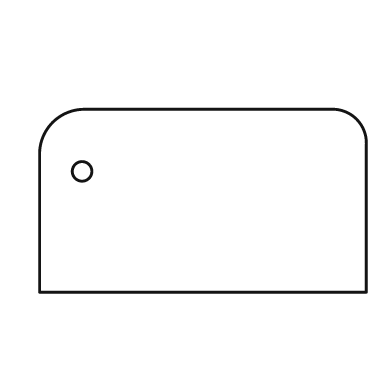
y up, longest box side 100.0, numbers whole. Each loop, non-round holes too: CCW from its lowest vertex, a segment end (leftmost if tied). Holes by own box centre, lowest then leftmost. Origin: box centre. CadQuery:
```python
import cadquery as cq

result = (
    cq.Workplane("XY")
    .moveTo(-50.0, -28.0)
    .lineTo(50.0, -28.0)
    .lineTo(50.0, 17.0)
    .threePointArc((47.0, 25.0), (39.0, 28.0))
    .lineTo(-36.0, 28.0)
    .threePointArc((-46.0, 24.0), (-50.0, 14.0))
    .close()
    .moveTo(-37.0, 9.0)
    .circle(3.0)
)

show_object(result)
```